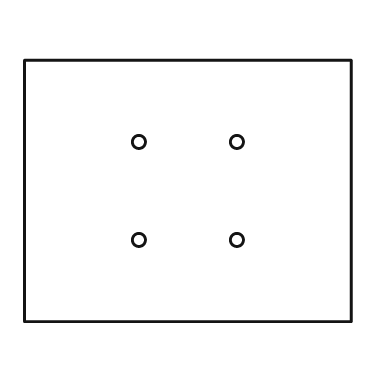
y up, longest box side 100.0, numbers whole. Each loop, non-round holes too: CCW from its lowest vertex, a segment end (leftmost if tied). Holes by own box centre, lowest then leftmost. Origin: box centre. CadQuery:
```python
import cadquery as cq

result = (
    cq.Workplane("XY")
    .moveTo(-50.0, -40.0)
    .lineTo(50.0, -40.0)
    .lineTo(50.0, 40.0)
    .lineTo(-50.0, 40.0)
    .close()
    .moveTo(-15.0, -15.0)
    .circle(2.0)
    .moveTo(15.0, -15.0)
    .circle(2.0)
    .moveTo(-15.0, 15.0)
    .circle(2.0)
    .moveTo(15.0, 15.0)
    .circle(2.0)
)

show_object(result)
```